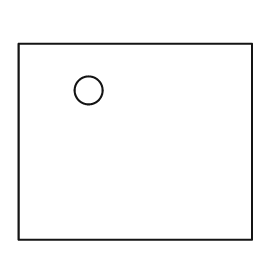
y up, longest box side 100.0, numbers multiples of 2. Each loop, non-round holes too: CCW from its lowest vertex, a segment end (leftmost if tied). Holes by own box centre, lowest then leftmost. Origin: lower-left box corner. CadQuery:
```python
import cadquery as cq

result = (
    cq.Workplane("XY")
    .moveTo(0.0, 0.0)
    .lineTo(100.0, 0.0)
    .lineTo(100.0, 84.0)
    .lineTo(0.0, 84.0)
    .close()
    .moveTo(30.0, 64.0)
    .circle(6.0)
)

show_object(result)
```